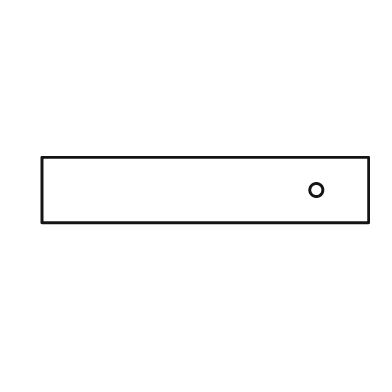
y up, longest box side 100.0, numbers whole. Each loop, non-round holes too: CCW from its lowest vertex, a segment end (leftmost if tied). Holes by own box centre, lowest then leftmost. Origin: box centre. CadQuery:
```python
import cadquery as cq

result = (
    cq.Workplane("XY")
    .moveTo(-50.0, -10.0)
    .lineTo(50.0, -10.0)
    .lineTo(50.0, 10.0)
    .lineTo(-50.0, 10.0)
    .close()
    .moveTo(34.0, 0.0)
    .circle(2.0)
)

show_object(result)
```